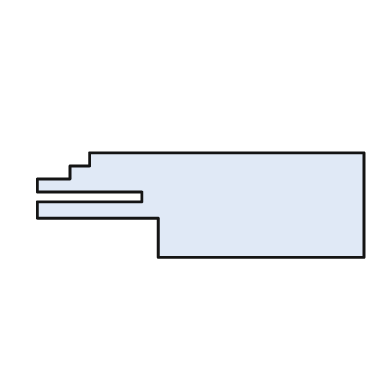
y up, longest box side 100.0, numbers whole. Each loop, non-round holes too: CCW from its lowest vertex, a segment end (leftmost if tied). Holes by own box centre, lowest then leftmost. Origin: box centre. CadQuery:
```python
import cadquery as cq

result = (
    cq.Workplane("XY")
    .moveTo(-13.0, -16.0)
    .lineTo(50.0, -16.0)
    .lineTo(50.0, 16.0)
    .lineTo(-34.0, 16.0)
    .lineTo(-34.0, 12.0)
    .lineTo(-40.0, 12.0)
    .lineTo(-40.0, 8.0)
    .lineTo(-50.0, 8.0)
    .lineTo(-50.0, 4.0)
    .lineTo(-18.0, 4.0)
    .lineTo(-18.0, 1.0)
    .lineTo(-50.0, 1.0)
    .lineTo(-50.0, -4.0)
    .lineTo(-13.0, -4.0)
    .close()
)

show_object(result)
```